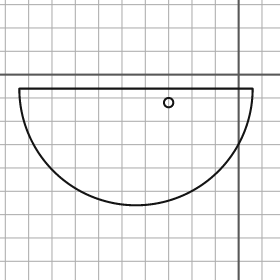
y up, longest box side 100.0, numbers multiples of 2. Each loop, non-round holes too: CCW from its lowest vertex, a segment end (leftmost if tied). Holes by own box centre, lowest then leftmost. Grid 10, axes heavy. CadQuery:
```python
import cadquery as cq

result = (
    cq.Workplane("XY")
    .moveTo(-94.0, -6.0)
    .threePointArc((-44.0, -56.0), (6.0, -6.0))
    .close()
    .moveTo(-30.0, -12.0)
    .circle(2.0)
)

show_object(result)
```